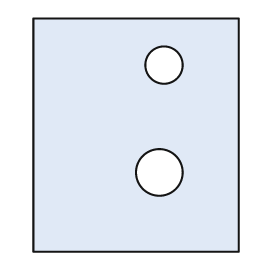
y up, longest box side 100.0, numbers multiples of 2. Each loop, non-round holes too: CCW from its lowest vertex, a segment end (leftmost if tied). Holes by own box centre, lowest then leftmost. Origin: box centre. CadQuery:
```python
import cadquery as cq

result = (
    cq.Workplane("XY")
    .moveTo(-44.0, -50.0)
    .lineTo(44.0, -50.0)
    .lineTo(44.0, 50.0)
    .lineTo(-44.0, 50.0)
    .close()
    .moveTo(10.0, -16.0)
    .circle(10.0)
    .moveTo(12.0, 30.0)
    .circle(8.0)
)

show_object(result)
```